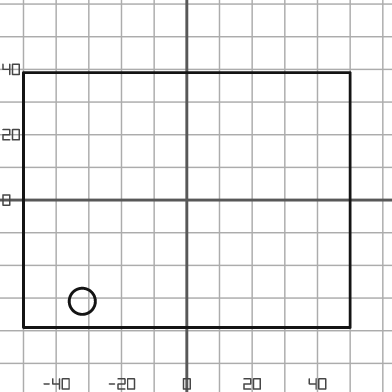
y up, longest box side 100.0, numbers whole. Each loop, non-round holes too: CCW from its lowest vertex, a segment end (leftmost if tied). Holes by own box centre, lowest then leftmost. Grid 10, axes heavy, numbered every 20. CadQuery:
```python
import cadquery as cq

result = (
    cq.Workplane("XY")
    .moveTo(-50.0, -39.0)
    .lineTo(50.0, -39.0)
    .lineTo(50.0, 39.0)
    .lineTo(-50.0, 39.0)
    .close()
    .moveTo(-32.0, -31.0)
    .circle(4.0)
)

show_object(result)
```